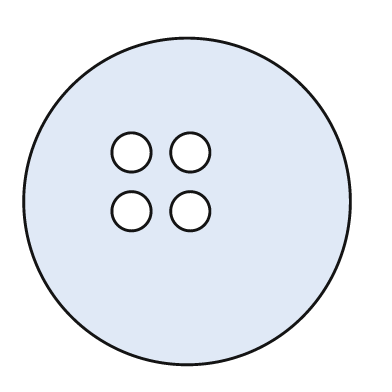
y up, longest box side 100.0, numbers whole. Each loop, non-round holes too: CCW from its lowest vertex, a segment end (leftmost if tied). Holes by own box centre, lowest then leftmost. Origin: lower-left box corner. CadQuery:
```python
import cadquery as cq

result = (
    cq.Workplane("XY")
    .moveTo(50.0, 50.0)
    .circle(50.0)
    .moveTo(33.0, 47.0)
    .circle(6.0)
    .moveTo(51.0, 47.0)
    .circle(6.0)
    .moveTo(33.0, 65.0)
    .circle(6.0)
    .moveTo(51.0, 65.0)
    .circle(6.0)
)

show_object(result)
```